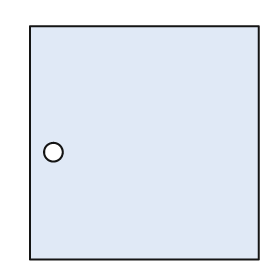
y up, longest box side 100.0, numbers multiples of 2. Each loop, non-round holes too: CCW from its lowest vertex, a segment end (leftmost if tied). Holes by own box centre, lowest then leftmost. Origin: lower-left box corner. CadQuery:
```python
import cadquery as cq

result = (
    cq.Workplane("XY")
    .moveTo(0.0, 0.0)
    .lineTo(98.0, 0.0)
    .lineTo(98.0, 100.0)
    .lineTo(0.0, 100.0)
    .close()
    .moveTo(10.0, 46.0)
    .circle(4.0)
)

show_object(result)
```